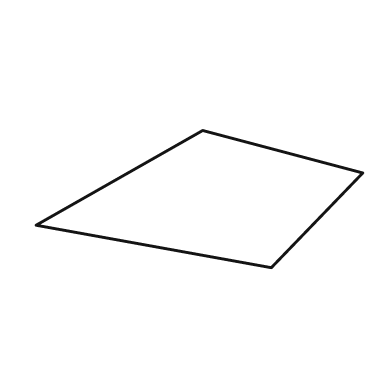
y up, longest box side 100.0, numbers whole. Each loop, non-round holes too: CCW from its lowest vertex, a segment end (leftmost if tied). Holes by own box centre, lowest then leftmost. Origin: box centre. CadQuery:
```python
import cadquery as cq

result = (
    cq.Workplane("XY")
    .moveTo(22.0, -21.0)
    .lineTo(50.0, 8.0)
    .lineTo(1.0, 21.0)
    .lineTo(-50.0, -8.0)
    .close()
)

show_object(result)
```